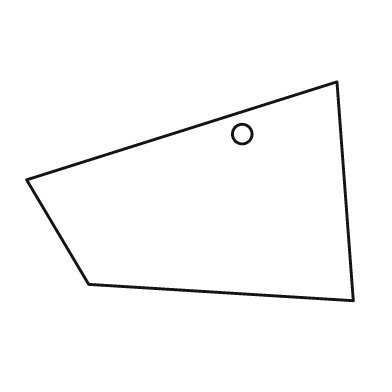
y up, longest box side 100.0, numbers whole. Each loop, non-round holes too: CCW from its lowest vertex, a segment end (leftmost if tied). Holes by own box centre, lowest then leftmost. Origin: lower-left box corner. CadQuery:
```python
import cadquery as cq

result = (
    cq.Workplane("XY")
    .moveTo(100.0, 0.0)
    .lineTo(95.0, 67.0)
    .lineTo(0.0, 37.0)
    .lineTo(19.0, 5.0)
    .close()
    .moveTo(66.0, 51.0)
    .circle(3.0)
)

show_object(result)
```